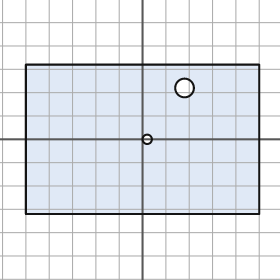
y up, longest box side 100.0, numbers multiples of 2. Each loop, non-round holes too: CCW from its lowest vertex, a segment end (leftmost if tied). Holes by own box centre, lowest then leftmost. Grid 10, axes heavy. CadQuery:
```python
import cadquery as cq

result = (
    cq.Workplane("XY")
    .moveTo(-50.0, -32.0)
    .lineTo(50.0, -32.0)
    .lineTo(50.0, 32.0)
    .lineTo(-50.0, 32.0)
    .close()
    .moveTo(2.0, 0.0)
    .circle(2.0)
    .moveTo(18.0, 22.0)
    .circle(4.0)
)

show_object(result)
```